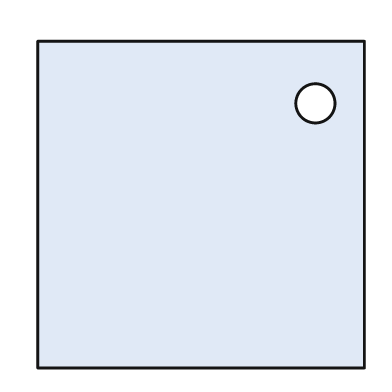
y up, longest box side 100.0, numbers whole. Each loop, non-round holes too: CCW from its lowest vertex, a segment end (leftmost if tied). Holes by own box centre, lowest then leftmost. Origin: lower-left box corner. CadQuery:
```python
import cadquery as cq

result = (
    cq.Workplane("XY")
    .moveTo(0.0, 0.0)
    .lineTo(100.0, 0.0)
    .lineTo(100.0, 100.0)
    .lineTo(0.0, 100.0)
    .close()
    .moveTo(85.0, 81.0)
    .circle(6.0)
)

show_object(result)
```